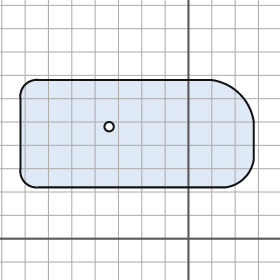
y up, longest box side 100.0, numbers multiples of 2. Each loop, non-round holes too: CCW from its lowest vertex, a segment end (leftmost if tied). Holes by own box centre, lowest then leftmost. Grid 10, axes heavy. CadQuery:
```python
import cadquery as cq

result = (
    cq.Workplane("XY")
    .moveTo(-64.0, 22.0)
    .lineTo(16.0, 22.0)
    .threePointArc((24.0, 26.0), (28.0, 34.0))
    .lineTo(28.0, 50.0)
    .threePointArc((22.0, 62.0), (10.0, 68.0))
    .lineTo(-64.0, 68.0)
    .threePointArc((-70.0, 66.0), (-72.0, 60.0))
    .lineTo(-72.0, 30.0)
    .threePointArc((-70.0, 24.0), (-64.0, 22.0))
    .close()
    .moveTo(-34.0, 48.0)
    .circle(2.0)
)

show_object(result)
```